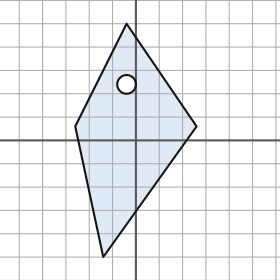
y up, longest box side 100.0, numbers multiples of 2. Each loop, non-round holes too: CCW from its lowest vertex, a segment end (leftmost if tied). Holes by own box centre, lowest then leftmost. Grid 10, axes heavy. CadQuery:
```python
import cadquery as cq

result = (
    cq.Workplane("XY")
    .moveTo(-14.0, -50.0)
    .lineTo(26.0, 6.0)
    .lineTo(-4.0, 50.0)
    .lineTo(-26.0, 6.0)
    .close()
    .moveTo(-4.0, 24.0)
    .circle(4.0)
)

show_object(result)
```